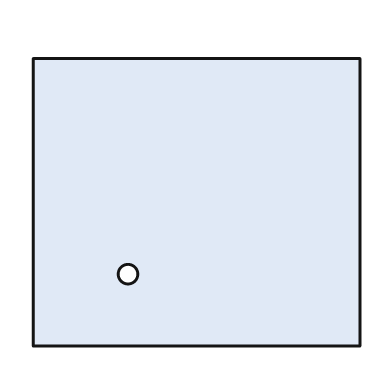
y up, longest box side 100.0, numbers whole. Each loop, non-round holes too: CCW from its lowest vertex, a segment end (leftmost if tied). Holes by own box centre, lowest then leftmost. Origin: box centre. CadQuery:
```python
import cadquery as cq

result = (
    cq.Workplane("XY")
    .moveTo(-50.0, -44.0)
    .lineTo(50.0, -44.0)
    .lineTo(50.0, 44.0)
    .lineTo(-50.0, 44.0)
    .close()
    .moveTo(-21.0, -22.0)
    .circle(3.0)
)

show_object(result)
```